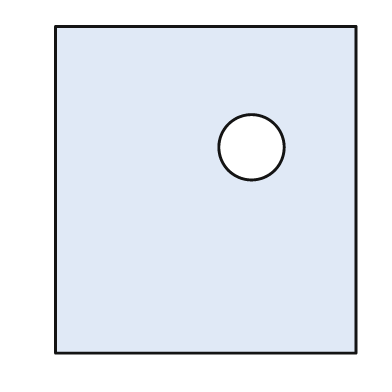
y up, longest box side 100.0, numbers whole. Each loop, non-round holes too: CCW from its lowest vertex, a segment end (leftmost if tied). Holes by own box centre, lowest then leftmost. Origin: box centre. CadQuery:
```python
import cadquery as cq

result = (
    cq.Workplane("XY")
    .moveTo(-46.0, -50.0)
    .lineTo(46.0, -50.0)
    .lineTo(46.0, 50.0)
    .lineTo(-46.0, 50.0)
    .close()
    .moveTo(14.0, 13.0)
    .circle(10.0)
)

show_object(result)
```